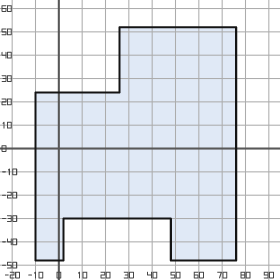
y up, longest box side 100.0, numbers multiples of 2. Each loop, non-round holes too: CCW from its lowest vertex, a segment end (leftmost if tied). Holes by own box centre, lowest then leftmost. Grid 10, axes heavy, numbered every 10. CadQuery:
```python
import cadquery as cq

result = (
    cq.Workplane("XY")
    .moveTo(-10.0, -48.0)
    .lineTo(2.0, -48.0)
    .lineTo(2.0, -30.0)
    .lineTo(48.0, -30.0)
    .lineTo(48.0, -48.0)
    .lineTo(76.0, -48.0)
    .lineTo(76.0, 52.0)
    .lineTo(26.0, 52.0)
    .lineTo(26.0, 24.0)
    .lineTo(-10.0, 24.0)
    .close()
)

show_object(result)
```